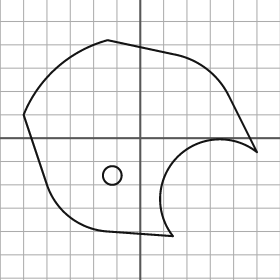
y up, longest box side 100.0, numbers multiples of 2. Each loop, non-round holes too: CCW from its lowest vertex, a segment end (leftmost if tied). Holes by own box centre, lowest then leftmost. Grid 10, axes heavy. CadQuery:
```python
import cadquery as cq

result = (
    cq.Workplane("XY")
    .moveTo(14.0, -42.0)
    .threePointArc((16.0, -8.0), (50.0, -6.0))
    .lineTo(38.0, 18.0)
    .threePointArc((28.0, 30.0), (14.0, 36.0))
    .lineTo(-14.0, 42.0)
    .threePointArc((-36.0, 30.0), (-50.0, 10.0))
    .lineTo(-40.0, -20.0)
    .threePointArc((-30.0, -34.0), (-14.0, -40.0))
    .close()
    .moveTo(-12.0, -16.0)
    .circle(4.0)
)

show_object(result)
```